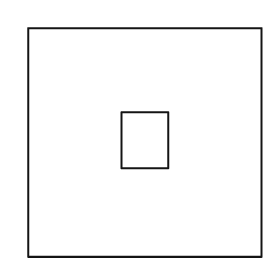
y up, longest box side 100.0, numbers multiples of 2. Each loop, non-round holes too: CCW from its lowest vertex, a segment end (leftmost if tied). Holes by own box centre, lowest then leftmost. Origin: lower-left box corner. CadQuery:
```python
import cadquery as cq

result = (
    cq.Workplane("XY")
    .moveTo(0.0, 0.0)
    .lineTo(100.0, 0.0)
    .lineTo(100.0, 98.0)
    .lineTo(0.0, 98.0)
    .close()
    .moveTo(40.0, 38.0)
    .lineTo(60.0, 38.0)
    .lineTo(60.0, 62.0)
    .lineTo(40.0, 62.0)
    .close()
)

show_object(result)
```